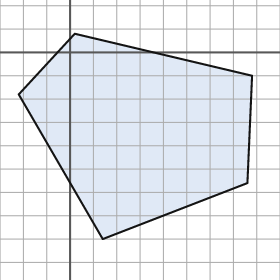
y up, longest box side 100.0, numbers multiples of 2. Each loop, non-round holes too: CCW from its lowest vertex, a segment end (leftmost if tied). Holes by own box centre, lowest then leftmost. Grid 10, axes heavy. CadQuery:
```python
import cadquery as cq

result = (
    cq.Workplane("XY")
    .moveTo(14.0, -80.0)
    .lineTo(76.0, -56.0)
    .lineTo(78.0, -10.0)
    .lineTo(2.0, 8.0)
    .lineTo(-22.0, -18.0)
    .close()
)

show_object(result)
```